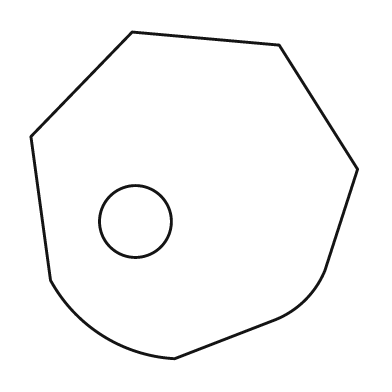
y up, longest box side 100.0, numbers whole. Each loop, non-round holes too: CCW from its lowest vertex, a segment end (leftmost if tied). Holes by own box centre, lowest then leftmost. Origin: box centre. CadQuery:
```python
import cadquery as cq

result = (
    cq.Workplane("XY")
    .moveTo(-6.0, -50.0)
    .lineTo(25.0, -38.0)
    .threePointArc((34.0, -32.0), (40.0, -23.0))
    .lineTo(50.0, 8.0)
    .lineTo(26.0, 46.0)
    .lineTo(-19.0, 50.0)
    .lineTo(-50.0, 18.0)
    .lineTo(-44.0, -26.0)
    .threePointArc((-28.0, -43.0), (-6.0, -50.0))
    .close()
    .moveTo(-18.0, -8.0)
    .circle(11.0)
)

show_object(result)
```